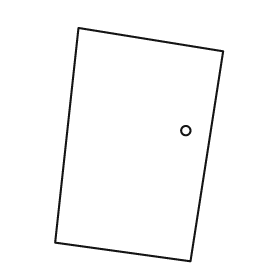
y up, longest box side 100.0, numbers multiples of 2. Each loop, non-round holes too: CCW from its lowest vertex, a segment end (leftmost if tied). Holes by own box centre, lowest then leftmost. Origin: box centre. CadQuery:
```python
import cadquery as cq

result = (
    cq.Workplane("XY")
    .moveTo(22.0, -50.0)
    .lineTo(36.0, 40.0)
    .lineTo(-26.0, 50.0)
    .lineTo(-36.0, -42.0)
    .close()
    .moveTo(20.0, 6.0)
    .circle(2.0)
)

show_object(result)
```